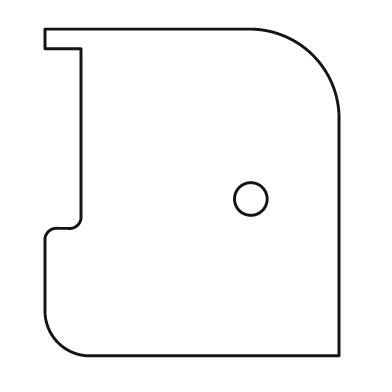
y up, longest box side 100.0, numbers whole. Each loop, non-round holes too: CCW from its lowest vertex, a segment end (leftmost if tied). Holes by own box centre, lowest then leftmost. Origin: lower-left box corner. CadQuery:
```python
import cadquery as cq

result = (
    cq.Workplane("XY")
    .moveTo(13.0, 0.0)
    .lineTo(90.0, 0.0)
    .lineTo(90.0, 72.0)
    .threePointArc((82.0, 92.0), (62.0, 100.0))
    .lineTo(0.0, 100.0)
    .lineTo(0.0, 94.0)
    .lineTo(11.0, 94.0)
    .lineTo(11.0, 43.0)
    .threePointArc((10.0, 40.0), (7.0, 39.0))
    .lineTo(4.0, 39.0)
    .threePointArc((1.0, 38.0), (0.0, 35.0))
    .lineTo(0.0, 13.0)
    .threePointArc((4.0, 4.0), (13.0, 0.0))
    .close()
    .moveTo(63.0, 48.0)
    .circle(5.0)
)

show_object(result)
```